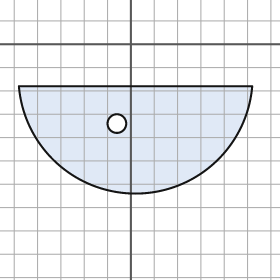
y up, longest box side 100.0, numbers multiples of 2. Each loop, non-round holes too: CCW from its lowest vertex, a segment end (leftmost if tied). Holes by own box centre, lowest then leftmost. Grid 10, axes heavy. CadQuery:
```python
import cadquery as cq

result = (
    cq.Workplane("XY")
    .moveTo(-48.0, -18.0)
    .threePointArc((2.0, -64.0), (52.0, -18.0))
    .close()
    .moveTo(-6.0, -34.0)
    .circle(4.0)
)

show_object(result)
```